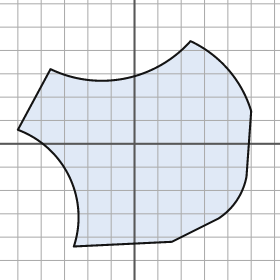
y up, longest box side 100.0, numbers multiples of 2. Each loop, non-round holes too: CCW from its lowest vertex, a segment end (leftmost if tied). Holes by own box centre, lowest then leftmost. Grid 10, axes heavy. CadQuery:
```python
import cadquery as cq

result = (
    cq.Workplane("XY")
    .moveTo(-26.0, -44.0)
    .lineTo(16.0, -42.0)
    .lineTo(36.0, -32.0)
    .threePointArc((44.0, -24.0), (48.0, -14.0))
    .lineTo(50.0, 14.0)
    .threePointArc((40.0, 32.0), (24.0, 44.0))
    .threePointArc((-4.0, 28.0), (-36.0, 32.0))
    .lineTo(-50.0, 6.0)
    .threePointArc((-28.0, -14.0), (-26.0, -44.0))
    .close()
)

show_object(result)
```